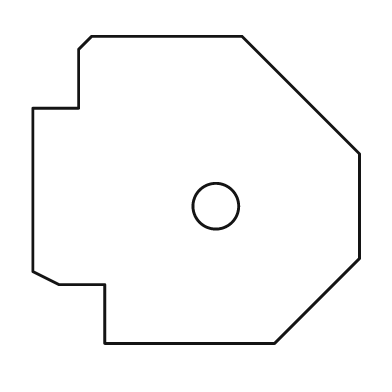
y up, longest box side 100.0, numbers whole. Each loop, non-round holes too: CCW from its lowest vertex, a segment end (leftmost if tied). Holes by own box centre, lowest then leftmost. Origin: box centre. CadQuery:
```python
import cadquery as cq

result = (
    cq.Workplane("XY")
    .moveTo(-28.0, -47.0)
    .lineTo(24.0, -47.0)
    .lineTo(50.0, -21.0)
    .lineTo(50.0, 11.0)
    .lineTo(14.0, 47.0)
    .lineTo(-32.0, 47.0)
    .lineTo(-36.0, 43.0)
    .lineTo(-36.0, 25.0)
    .lineTo(-50.0, 25.0)
    .lineTo(-50.0, -25.0)
    .lineTo(-42.0, -29.0)
    .lineTo(-28.0, -29.0)
    .close()
    .moveTo(6.0, -5.0)
    .circle(7.0)
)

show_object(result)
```